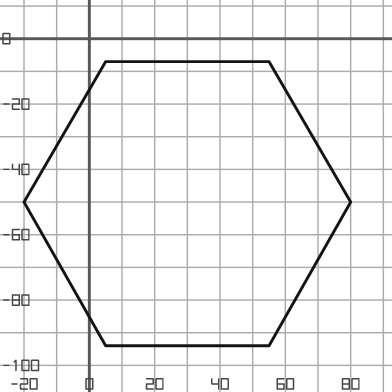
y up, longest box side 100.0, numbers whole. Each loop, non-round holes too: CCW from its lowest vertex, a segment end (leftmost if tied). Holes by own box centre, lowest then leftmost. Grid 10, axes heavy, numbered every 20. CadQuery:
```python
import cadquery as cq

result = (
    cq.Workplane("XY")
    .moveTo(5.0, -94.0)
    .lineTo(55.0, -94.0)
    .lineTo(80.0, -50.0)
    .lineTo(55.0, -7.0)
    .lineTo(5.0, -7.0)
    .lineTo(-20.0, -50.0)
    .close()
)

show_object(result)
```